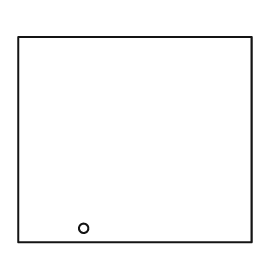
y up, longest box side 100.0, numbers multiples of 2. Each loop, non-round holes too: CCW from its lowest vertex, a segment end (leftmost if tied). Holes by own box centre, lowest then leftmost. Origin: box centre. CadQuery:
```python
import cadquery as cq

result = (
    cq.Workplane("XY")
    .moveTo(-50.0, -44.0)
    .lineTo(50.0, -44.0)
    .lineTo(50.0, 44.0)
    .lineTo(-50.0, 44.0)
    .close()
    .moveTo(-22.0, -38.0)
    .circle(2.0)
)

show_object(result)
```